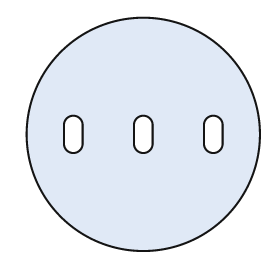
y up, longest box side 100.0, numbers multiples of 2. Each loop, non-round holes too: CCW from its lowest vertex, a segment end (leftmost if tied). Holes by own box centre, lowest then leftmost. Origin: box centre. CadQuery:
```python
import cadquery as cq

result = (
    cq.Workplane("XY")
    .moveTo(0.0, 0.0)
    .circle(50.0)
    .moveTo(-34.0, -4.0)
    .threePointArc((-30.0, -8.0), (-26.0, -4.0))
    .lineTo(-26.0, 4.0)
    .threePointArc((-30.0, 8.0), (-34.0, 4.0))
    .close()
    .moveTo(-4.0, -4.0)
    .threePointArc((0.0, -8.0), (4.0, -4.0))
    .lineTo(4.0, 4.0)
    .threePointArc((0.0, 8.0), (-4.0, 4.0))
    .close()
    .moveTo(26.0, -4.0)
    .threePointArc((30.0, -8.0), (34.0, -4.0))
    .lineTo(34.0, 4.0)
    .threePointArc((30.0, 8.0), (26.0, 4.0))
    .close()
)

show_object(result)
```